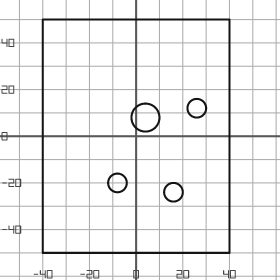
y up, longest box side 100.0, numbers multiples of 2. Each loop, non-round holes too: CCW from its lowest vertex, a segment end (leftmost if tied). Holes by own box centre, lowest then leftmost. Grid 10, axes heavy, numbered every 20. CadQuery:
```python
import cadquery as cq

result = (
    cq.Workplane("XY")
    .moveTo(-40.0, -50.0)
    .lineTo(40.0, -50.0)
    .lineTo(40.0, 50.0)
    .lineTo(-40.0, 50.0)
    .close()
    .moveTo(16.0, -24.0)
    .circle(4.0)
    .moveTo(-8.0, -20.0)
    .circle(4.0)
    .moveTo(4.0, 8.0)
    .circle(6.0)
    .moveTo(26.0, 12.0)
    .circle(4.0)
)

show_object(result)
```